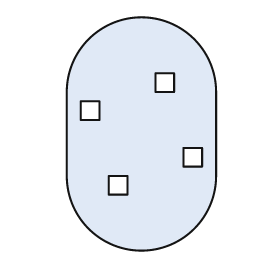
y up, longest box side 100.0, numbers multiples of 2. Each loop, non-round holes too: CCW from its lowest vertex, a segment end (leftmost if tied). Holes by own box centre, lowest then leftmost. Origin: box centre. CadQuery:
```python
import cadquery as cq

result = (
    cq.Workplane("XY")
    .moveTo(-32.0, -18.0)
    .threePointArc((0.0, -50.0), (32.0, -18.0))
    .lineTo(32.0, 18.0)
    .threePointArc((0.0, 50.0), (-32.0, 18.0))
    .close()
    .moveTo(-14.0, -26.0)
    .lineTo(-6.0, -26.0)
    .lineTo(-6.0, -18.0)
    .lineTo(-14.0, -18.0)
    .close()
    .moveTo(18.0, -14.0)
    .lineTo(26.0, -14.0)
    .lineTo(26.0, -6.0)
    .lineTo(18.0, -6.0)
    .close()
    .moveTo(-26.0, 6.0)
    .lineTo(-18.0, 6.0)
    .lineTo(-18.0, 14.0)
    .lineTo(-26.0, 14.0)
    .close()
    .moveTo(6.0, 18.0)
    .lineTo(14.0, 18.0)
    .lineTo(14.0, 26.0)
    .lineTo(6.0, 26.0)
    .close()
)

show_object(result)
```